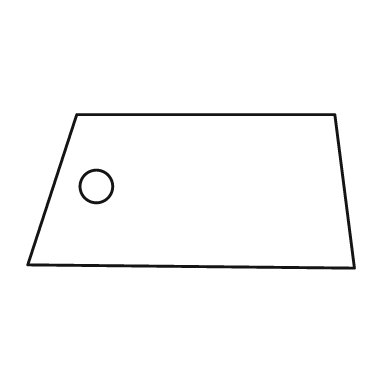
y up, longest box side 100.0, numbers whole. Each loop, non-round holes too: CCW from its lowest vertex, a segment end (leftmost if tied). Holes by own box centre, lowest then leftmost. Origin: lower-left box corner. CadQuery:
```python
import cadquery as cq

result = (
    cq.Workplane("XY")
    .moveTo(100.0, 0.0)
    .lineTo(94.0, 47.0)
    .lineTo(15.0, 47.0)
    .lineTo(0.0, 1.0)
    .close()
    .moveTo(21.0, 25.0)
    .circle(5.0)
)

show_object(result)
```